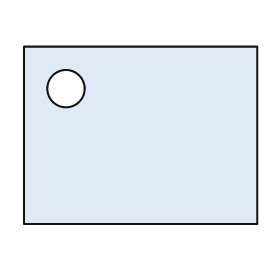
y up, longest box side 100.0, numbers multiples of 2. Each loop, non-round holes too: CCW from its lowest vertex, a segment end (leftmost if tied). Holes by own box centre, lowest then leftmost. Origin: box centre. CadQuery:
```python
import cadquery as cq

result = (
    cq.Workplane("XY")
    .moveTo(-50.0, -38.0)
    .lineTo(50.0, -38.0)
    .lineTo(50.0, 38.0)
    .lineTo(-50.0, 38.0)
    .close()
    .moveTo(-32.0, 20.0)
    .circle(8.0)
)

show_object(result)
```